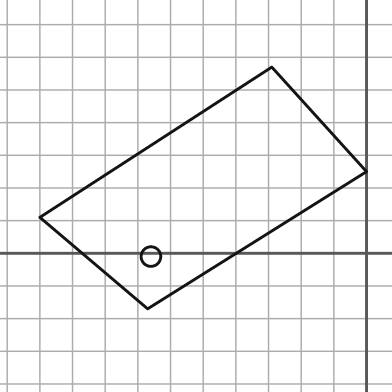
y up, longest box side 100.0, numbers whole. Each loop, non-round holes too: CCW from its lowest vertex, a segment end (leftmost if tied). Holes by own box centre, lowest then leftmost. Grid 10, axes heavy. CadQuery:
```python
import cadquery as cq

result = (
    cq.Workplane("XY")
    .moveTo(-67.0, -17.0)
    .lineTo(0.0, 25.0)
    .lineTo(-29.0, 57.0)
    .lineTo(-100.0, 11.0)
    .close()
    .moveTo(-66.0, -1.0)
    .circle(3.0)
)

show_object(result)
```